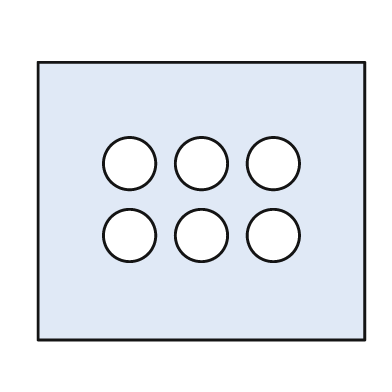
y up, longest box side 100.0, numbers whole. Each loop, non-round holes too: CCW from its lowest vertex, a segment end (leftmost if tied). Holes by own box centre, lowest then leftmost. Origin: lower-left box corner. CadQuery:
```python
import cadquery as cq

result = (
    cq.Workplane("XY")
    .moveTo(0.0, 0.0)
    .lineTo(100.0, 0.0)
    .lineTo(100.0, 85.0)
    .lineTo(0.0, 85.0)
    .close()
    .moveTo(28.0, 32.0)
    .circle(8.0)
    .moveTo(50.0, 32.0)
    .circle(8.0)
    .moveTo(72.0, 32.0)
    .circle(8.0)
    .moveTo(28.0, 54.0)
    .circle(8.0)
    .moveTo(50.0, 54.0)
    .circle(8.0)
    .moveTo(72.0, 54.0)
    .circle(8.0)
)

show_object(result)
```